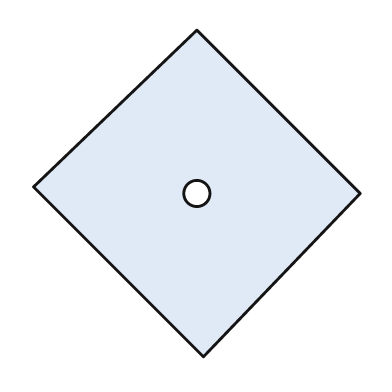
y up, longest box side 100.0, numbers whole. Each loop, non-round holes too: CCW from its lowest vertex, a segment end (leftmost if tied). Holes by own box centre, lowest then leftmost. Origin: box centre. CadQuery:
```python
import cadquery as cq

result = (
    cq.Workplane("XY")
    .moveTo(2.0, -50.0)
    .lineTo(50.0, 0.0)
    .lineTo(0.0, 50.0)
    .lineTo(-50.0, 2.0)
    .close()
    .moveTo(0.0, 0.0)
    .circle(4.0)
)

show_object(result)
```